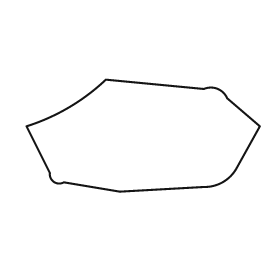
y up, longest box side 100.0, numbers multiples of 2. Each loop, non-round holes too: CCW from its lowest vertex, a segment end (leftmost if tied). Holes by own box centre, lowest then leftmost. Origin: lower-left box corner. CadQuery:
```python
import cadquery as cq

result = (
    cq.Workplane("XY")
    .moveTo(40.0, 0.0)
    .lineTo(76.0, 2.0)
    .threePointArc((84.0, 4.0), (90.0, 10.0))
    .lineTo(100.0, 28.0)
    .lineTo(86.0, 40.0)
    .threePointArc((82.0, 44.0), (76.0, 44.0))
    .lineTo(34.0, 48.0)
    .threePointArc((18.0, 36.0), (0.0, 28.0))
    .lineTo(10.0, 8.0)
    .threePointArc((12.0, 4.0), (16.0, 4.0))
    .close()
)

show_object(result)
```